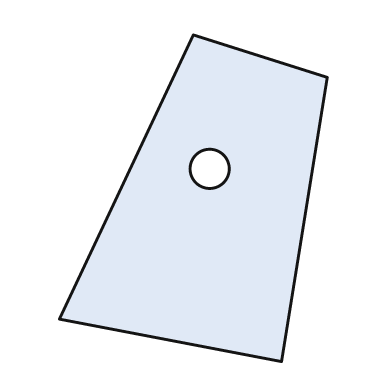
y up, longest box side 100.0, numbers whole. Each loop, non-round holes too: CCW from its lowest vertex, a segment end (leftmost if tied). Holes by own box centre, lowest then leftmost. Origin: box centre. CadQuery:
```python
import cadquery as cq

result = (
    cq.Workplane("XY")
    .moveTo(27.0, -50.0)
    .lineTo(41.0, 37.0)
    .lineTo(0.0, 50.0)
    .lineTo(-41.0, -37.0)
    .close()
    .moveTo(5.0, 9.0)
    .circle(6.0)
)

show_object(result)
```